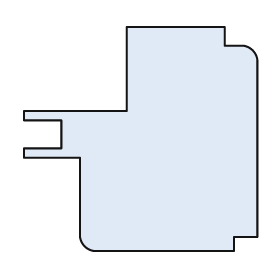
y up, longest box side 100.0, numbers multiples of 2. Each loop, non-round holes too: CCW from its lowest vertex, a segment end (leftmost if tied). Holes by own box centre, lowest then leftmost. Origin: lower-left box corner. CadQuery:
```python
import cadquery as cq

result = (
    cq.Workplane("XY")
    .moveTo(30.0, 0.0)
    .lineTo(90.0, 0.0)
    .lineTo(90.0, 6.0)
    .lineTo(100.0, 6.0)
    .lineTo(100.0, 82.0)
    .threePointArc((98.0, 86.0), (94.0, 88.0))
    .lineTo(86.0, 88.0)
    .lineTo(86.0, 96.0)
    .lineTo(44.0, 96.0)
    .lineTo(44.0, 60.0)
    .lineTo(0.0, 60.0)
    .lineTo(0.0, 56.0)
    .lineTo(16.0, 56.0)
    .lineTo(16.0, 44.0)
    .lineTo(0.0, 44.0)
    .lineTo(0.0, 40.0)
    .lineTo(24.0, 40.0)
    .lineTo(24.0, 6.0)
    .threePointArc((26.0, 2.0), (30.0, 0.0))
    .close()
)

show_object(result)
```